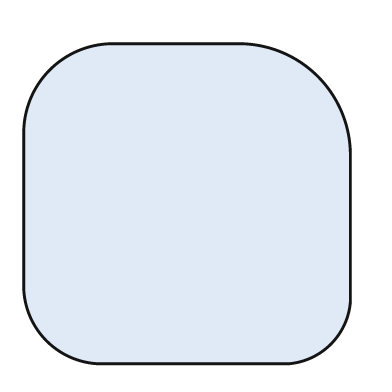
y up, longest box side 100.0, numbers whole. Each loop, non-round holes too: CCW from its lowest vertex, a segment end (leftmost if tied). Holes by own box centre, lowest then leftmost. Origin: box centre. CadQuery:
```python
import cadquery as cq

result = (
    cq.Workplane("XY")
    .moveTo(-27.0, -49.0)
    .lineTo(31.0, -49.0)
    .threePointArc((44.0, -43.0), (50.0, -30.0))
    .lineTo(50.0, 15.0)
    .threePointArc((40.0, 39.0), (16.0, 49.0))
    .lineTo(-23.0, 49.0)
    .threePointArc((-42.0, 41.0), (-50.0, 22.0))
    .lineTo(-50.0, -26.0)
    .threePointArc((-43.0, -42.0), (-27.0, -49.0))
    .close()
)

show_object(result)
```